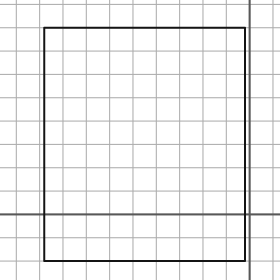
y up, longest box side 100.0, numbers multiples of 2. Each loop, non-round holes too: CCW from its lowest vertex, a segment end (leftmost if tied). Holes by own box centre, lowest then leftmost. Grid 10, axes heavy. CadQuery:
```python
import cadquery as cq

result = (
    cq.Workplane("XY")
    .moveTo(-88.0, -20.0)
    .lineTo(-2.0, -20.0)
    .lineTo(-2.0, 80.0)
    .lineTo(-88.0, 80.0)
    .close()
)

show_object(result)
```